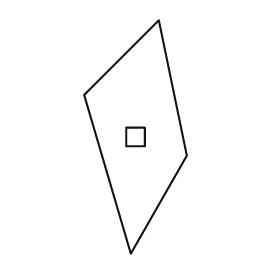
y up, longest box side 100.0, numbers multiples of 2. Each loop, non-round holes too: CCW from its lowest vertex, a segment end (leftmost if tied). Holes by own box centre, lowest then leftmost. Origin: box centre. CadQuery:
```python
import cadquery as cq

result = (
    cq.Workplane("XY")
    .moveTo(-2.0, -50.0)
    .lineTo(22.0, -8.0)
    .lineTo(10.0, 50.0)
    .lineTo(-22.0, 18.0)
    .close()
    .moveTo(-4.0, -4.0)
    .lineTo(4.0, -4.0)
    .lineTo(4.0, 4.0)
    .lineTo(-4.0, 4.0)
    .close()
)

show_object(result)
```